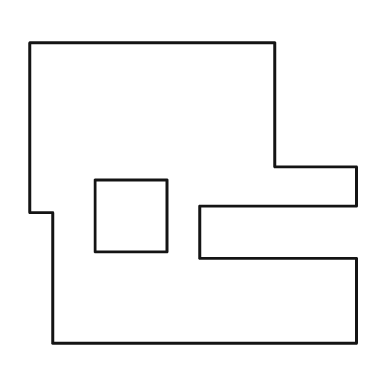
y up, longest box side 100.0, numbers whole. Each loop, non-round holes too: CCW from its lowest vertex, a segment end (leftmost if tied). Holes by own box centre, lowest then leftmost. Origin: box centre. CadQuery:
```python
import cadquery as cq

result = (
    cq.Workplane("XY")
    .moveTo(-43.0, -46.0)
    .lineTo(50.0, -46.0)
    .lineTo(50.0, -20.0)
    .lineTo(2.0, -20.0)
    .lineTo(2.0, -4.0)
    .lineTo(50.0, -4.0)
    .lineTo(50.0, 8.0)
    .lineTo(25.0, 8.0)
    .lineTo(25.0, 46.0)
    .lineTo(-50.0, 46.0)
    .lineTo(-50.0, -6.0)
    .lineTo(-43.0, -6.0)
    .close()
    .moveTo(-30.0, -18.0)
    .lineTo(-8.0, -18.0)
    .lineTo(-8.0, 4.0)
    .lineTo(-30.0, 4.0)
    .close()
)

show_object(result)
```